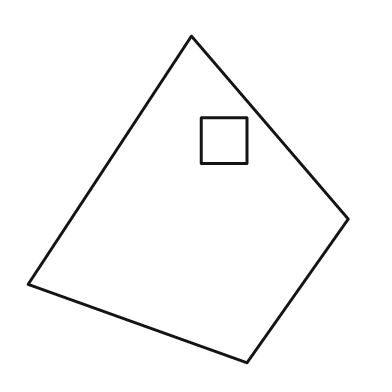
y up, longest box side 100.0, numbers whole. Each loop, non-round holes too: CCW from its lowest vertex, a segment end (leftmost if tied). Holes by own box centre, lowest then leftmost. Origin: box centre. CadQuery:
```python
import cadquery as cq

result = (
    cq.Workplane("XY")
    .moveTo(18.0, -50.0)
    .lineTo(49.0, -6.0)
    .lineTo(1.0, 50.0)
    .lineTo(-49.0, -26.0)
    .close()
    .moveTo(4.0, 11.0)
    .lineTo(18.0, 11.0)
    .lineTo(18.0, 25.0)
    .lineTo(4.0, 25.0)
    .close()
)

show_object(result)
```